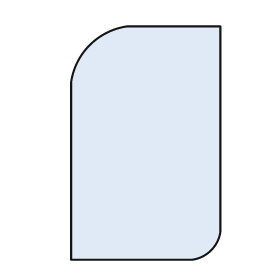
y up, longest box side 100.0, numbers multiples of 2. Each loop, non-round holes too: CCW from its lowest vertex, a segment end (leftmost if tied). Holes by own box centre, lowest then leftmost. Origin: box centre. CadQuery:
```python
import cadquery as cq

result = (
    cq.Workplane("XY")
    .moveTo(-32.0, -50.0)
    .lineTo(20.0, -50.0)
    .threePointArc((28.0, -46.0), (32.0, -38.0))
    .lineTo(32.0, 50.0)
    .lineTo(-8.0, 50.0)
    .threePointArc((-24.0, 42.0), (-32.0, 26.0))
    .close()
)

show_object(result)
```